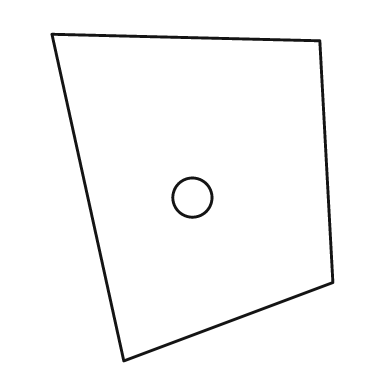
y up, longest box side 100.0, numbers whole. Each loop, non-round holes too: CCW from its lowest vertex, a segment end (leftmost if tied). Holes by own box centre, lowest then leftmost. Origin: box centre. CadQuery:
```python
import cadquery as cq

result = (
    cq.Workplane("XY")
    .moveTo(-21.0, -50.0)
    .lineTo(43.0, -26.0)
    .lineTo(39.0, 48.0)
    .lineTo(-43.0, 50.0)
    .close()
    .moveTo(0.0, 0.0)
    .circle(6.0)
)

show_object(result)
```